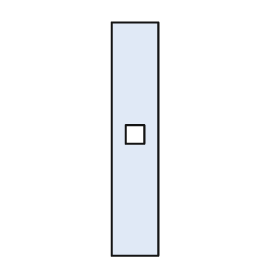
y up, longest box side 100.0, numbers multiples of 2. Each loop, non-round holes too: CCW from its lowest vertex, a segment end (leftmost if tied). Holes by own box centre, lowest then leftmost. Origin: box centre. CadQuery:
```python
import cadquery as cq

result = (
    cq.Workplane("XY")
    .moveTo(-10.0, -50.0)
    .lineTo(10.0, -50.0)
    .lineTo(10.0, 50.0)
    .lineTo(-10.0, 50.0)
    .close()
    .moveTo(-4.0, -2.0)
    .lineTo(4.0, -2.0)
    .lineTo(4.0, 6.0)
    .lineTo(-4.0, 6.0)
    .close()
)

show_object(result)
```